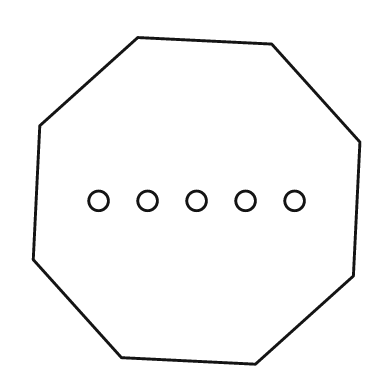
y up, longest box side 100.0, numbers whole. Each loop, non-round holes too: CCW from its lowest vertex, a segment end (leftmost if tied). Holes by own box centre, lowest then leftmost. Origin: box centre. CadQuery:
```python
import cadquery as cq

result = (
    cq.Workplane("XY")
    .moveTo(18.0, -50.0)
    .lineTo(48.0, -23.0)
    .lineTo(50.0, 18.0)
    .lineTo(23.0, 48.0)
    .lineTo(-18.0, 50.0)
    .lineTo(-48.0, 23.0)
    .lineTo(-50.0, -18.0)
    .lineTo(-23.0, -48.0)
    .close()
    .moveTo(-30.0, 0.0)
    .circle(3.0)
    .moveTo(-15.0, 0.0)
    .circle(3.0)
    .moveTo(0.0, 0.0)
    .circle(3.0)
    .moveTo(15.0, 0.0)
    .circle(3.0)
    .moveTo(30.0, 0.0)
    .circle(3.0)
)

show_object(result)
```